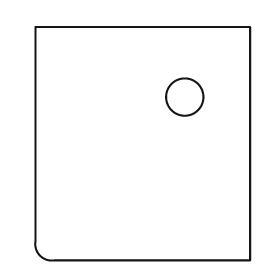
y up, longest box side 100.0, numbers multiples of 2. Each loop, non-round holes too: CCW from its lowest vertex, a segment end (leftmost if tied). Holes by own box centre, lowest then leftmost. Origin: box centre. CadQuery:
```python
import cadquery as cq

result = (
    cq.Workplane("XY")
    .moveTo(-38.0, -50.0)
    .lineTo(46.0, -50.0)
    .lineTo(46.0, 50.0)
    .lineTo(-46.0, 50.0)
    .lineTo(-46.0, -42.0)
    .threePointArc((-44.0, -48.0), (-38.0, -50.0))
    .close()
    .moveTo(18.0, 20.0)
    .circle(8.0)
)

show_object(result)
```